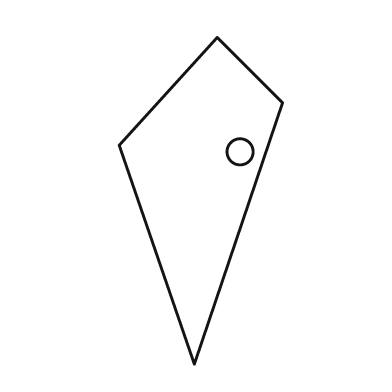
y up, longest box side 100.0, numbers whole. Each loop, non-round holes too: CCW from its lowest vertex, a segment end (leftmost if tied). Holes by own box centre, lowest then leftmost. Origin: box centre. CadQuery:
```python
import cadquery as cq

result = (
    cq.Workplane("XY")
    .moveTo(-2.0, -50.0)
    .lineTo(25.0, 30.0)
    .lineTo(5.0, 50.0)
    .lineTo(-25.0, 17.0)
    .close()
    .moveTo(12.0, 15.0)
    .circle(4.0)
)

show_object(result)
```